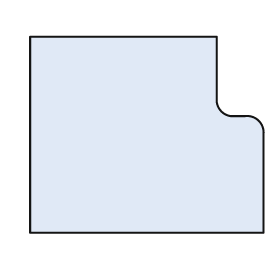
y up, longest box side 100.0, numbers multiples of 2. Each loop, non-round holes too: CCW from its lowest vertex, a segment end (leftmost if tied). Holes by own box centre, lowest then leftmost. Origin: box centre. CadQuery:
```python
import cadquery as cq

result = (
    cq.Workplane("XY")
    .moveTo(-50.0, -42.0)
    .lineTo(50.0, -42.0)
    .lineTo(50.0, 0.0)
    .threePointArc((48.0, 6.0), (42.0, 8.0))
    .lineTo(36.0, 8.0)
    .threePointArc((32.0, 10.0), (30.0, 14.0))
    .lineTo(30.0, 42.0)
    .lineTo(-50.0, 42.0)
    .close()
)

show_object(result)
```